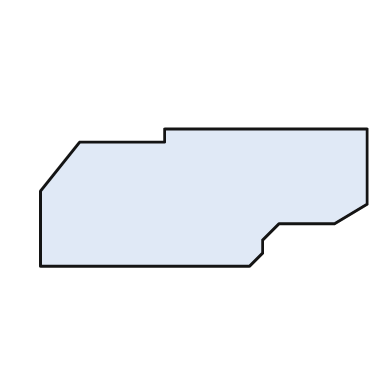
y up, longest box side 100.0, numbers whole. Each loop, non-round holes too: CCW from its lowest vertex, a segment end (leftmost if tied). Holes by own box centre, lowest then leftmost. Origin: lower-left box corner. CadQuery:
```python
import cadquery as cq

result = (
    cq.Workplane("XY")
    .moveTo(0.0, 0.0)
    .lineTo(64.0, 0.0)
    .lineTo(68.0, 4.0)
    .lineTo(68.0, 8.0)
    .lineTo(73.0, 13.0)
    .lineTo(90.0, 13.0)
    .lineTo(100.0, 19.0)
    .lineTo(100.0, 42.0)
    .lineTo(38.0, 42.0)
    .lineTo(38.0, 38.0)
    .lineTo(12.0, 38.0)
    .lineTo(0.0, 23.0)
    .close()
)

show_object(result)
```